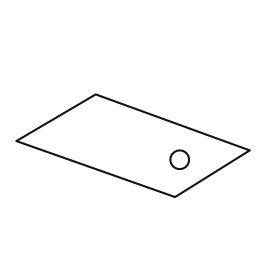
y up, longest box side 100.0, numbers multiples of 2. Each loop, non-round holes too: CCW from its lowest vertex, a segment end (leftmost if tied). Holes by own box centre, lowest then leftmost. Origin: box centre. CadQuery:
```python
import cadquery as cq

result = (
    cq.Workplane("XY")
    .moveTo(18.0, -22.0)
    .lineTo(50.0, -2.0)
    .lineTo(-16.0, 22.0)
    .lineTo(-50.0, 2.0)
    .close()
    .moveTo(20.0, -6.0)
    .circle(4.0)
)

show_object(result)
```